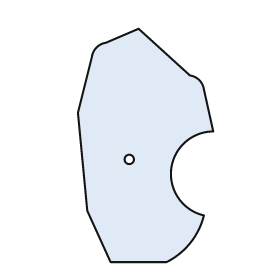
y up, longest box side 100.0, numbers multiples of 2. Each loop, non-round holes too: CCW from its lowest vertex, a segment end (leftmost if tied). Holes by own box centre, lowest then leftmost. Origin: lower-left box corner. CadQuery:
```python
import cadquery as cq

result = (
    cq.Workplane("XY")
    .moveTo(14.0, 0.0)
    .lineTo(38.0, 0.0)
    .threePointArc((48.0, 8.0), (54.0, 20.0))
    .threePointArc((40.0, 40.0), (58.0, 56.0))
    .lineTo(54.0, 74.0)
    .threePointArc((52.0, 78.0), (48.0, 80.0))
    .lineTo(26.0, 100.0)
    .lineTo(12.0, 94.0)
    .threePointArc((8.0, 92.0), (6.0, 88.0))
    .lineTo(0.0, 64.0)
    .lineTo(4.0, 22.0)
    .close()
    .moveTo(22.0, 44.0)
    .circle(2.0)
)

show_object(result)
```